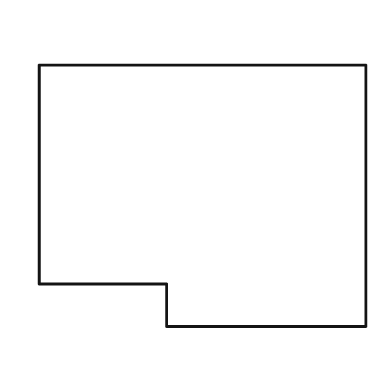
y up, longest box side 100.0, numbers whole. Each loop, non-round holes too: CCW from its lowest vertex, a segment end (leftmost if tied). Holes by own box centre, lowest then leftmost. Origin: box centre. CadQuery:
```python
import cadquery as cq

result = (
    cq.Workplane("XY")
    .moveTo(-11.0, -40.0)
    .lineTo(50.0, -40.0)
    .lineTo(50.0, 40.0)
    .lineTo(-50.0, 40.0)
    .lineTo(-50.0, -27.0)
    .lineTo(-11.0, -27.0)
    .close()
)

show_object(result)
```